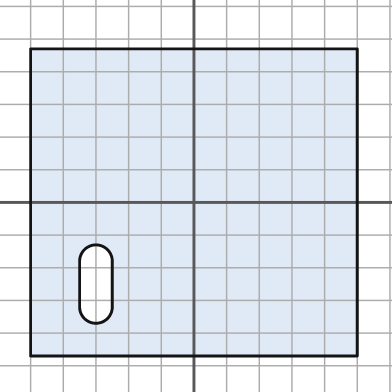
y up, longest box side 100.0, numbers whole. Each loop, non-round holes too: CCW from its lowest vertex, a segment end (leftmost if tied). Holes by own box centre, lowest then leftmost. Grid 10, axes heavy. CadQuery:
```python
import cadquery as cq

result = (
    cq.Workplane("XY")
    .moveTo(-50.0, -47.0)
    .lineTo(50.0, -47.0)
    .lineTo(50.0, 47.0)
    .lineTo(-50.0, 47.0)
    .close()
    .moveTo(-35.0, -32.0)
    .threePointArc((-30.0, -37.0), (-25.0, -32.0))
    .lineTo(-25.0, -18.0)
    .threePointArc((-30.0, -13.0), (-35.0, -18.0))
    .close()
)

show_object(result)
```